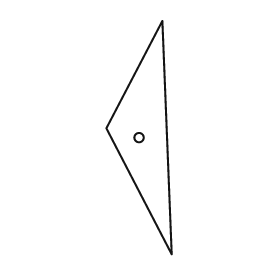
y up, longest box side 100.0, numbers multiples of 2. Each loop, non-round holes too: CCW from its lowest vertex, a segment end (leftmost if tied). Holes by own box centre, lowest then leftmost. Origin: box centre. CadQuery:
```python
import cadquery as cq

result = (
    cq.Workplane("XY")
    .moveTo(14.0, -50.0)
    .lineTo(10.0, 50.0)
    .lineTo(-14.0, 4.0)
    .close()
    .moveTo(0.0, 0.0)
    .circle(2.0)
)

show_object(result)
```